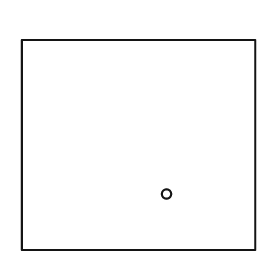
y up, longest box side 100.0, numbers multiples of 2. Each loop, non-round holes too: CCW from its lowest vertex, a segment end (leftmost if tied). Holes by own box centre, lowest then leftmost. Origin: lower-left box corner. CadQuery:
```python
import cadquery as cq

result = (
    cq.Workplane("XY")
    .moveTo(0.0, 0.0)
    .lineTo(100.0, 0.0)
    .lineTo(100.0, 90.0)
    .lineTo(0.0, 90.0)
    .close()
    .moveTo(62.0, 24.0)
    .circle(2.0)
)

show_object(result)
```